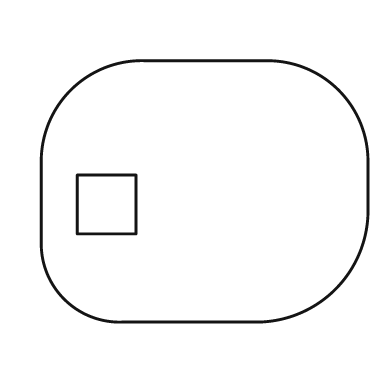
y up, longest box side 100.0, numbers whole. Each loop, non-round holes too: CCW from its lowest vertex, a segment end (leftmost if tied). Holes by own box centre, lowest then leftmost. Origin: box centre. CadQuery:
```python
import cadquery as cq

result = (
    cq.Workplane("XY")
    .moveTo(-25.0, -40.0)
    .lineTo(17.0, -40.0)
    .threePointArc((40.0, -30.0), (50.0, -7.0))
    .lineTo(50.0, 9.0)
    .threePointArc((41.0, 31.0), (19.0, 40.0))
    .lineTo(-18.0, 40.0)
    .threePointArc((-41.0, 31.0), (-50.0, 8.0))
    .lineTo(-50.0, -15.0)
    .threePointArc((-43.0, -33.0), (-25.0, -40.0))
    .close()
    .moveTo(-39.0, -13.0)
    .lineTo(-21.0, -13.0)
    .lineTo(-21.0, 5.0)
    .lineTo(-39.0, 5.0)
    .close()
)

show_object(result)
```